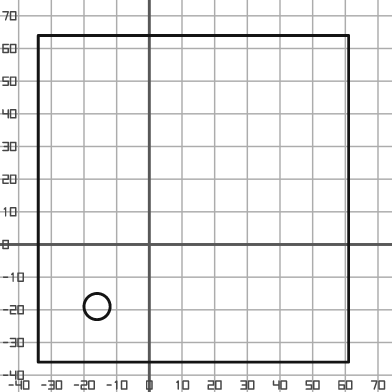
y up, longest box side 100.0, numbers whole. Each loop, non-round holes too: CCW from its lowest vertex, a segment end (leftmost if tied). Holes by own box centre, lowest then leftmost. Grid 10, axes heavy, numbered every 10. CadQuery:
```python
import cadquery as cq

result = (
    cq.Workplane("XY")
    .moveTo(-34.0, -36.0)
    .lineTo(61.0, -36.0)
    .lineTo(61.0, 64.0)
    .lineTo(-34.0, 64.0)
    .close()
    .moveTo(-16.0, -19.0)
    .circle(4.0)
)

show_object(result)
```